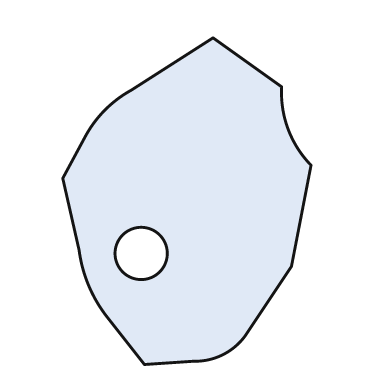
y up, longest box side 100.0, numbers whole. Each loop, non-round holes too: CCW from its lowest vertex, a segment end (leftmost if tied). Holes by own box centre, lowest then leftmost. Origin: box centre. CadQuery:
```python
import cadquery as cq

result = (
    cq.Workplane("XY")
    .moveTo(-13.0, -50.0)
    .lineTo(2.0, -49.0)
    .threePointArc((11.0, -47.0), (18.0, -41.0))
    .lineTo(32.0, -20.0)
    .lineTo(38.0, 11.0)
    .threePointArc((31.0, 22.0), (29.0, 35.0))
    .lineTo(8.0, 50.0)
    .lineTo(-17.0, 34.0)
    .threePointArc((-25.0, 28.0), (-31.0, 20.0))
    .lineTo(-38.0, 7.0)
    .lineTo(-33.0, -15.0)
    .threePointArc((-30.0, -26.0), (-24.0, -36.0))
    .close()
    .moveTo(-14.0, -16.0)
    .circle(8.0)
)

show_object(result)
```